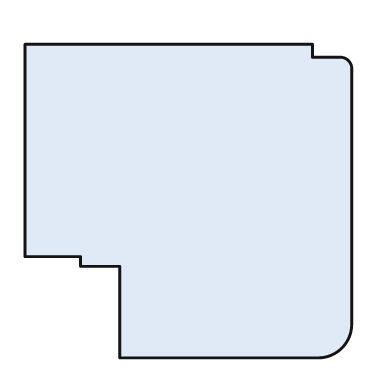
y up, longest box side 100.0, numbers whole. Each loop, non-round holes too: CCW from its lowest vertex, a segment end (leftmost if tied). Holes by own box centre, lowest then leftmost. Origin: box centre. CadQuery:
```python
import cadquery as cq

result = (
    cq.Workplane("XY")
    .moveTo(-21.0, -48.0)
    .lineTo(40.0, -48.0)
    .threePointArc((47.0, -45.0), (50.0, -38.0))
    .lineTo(50.0, 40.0)
    .threePointArc((49.0, 43.0), (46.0, 44.0))
    .lineTo(38.0, 44.0)
    .lineTo(38.0, 48.0)
    .lineTo(-50.0, 48.0)
    .lineTo(-50.0, -17.0)
    .lineTo(-33.0, -17.0)
    .lineTo(-33.0, -20.0)
    .lineTo(-21.0, -20.0)
    .close()
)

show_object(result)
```